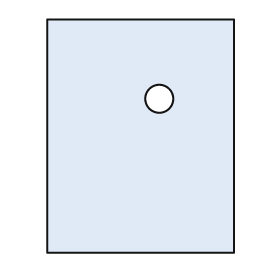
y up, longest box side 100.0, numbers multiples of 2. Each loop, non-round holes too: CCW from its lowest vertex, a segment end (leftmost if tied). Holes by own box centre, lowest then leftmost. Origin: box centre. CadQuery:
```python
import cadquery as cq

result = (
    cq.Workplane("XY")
    .moveTo(-40.0, -50.0)
    .lineTo(40.0, -50.0)
    .lineTo(40.0, 50.0)
    .lineTo(-40.0, 50.0)
    .close()
    .moveTo(8.0, 16.0)
    .circle(6.0)
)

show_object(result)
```